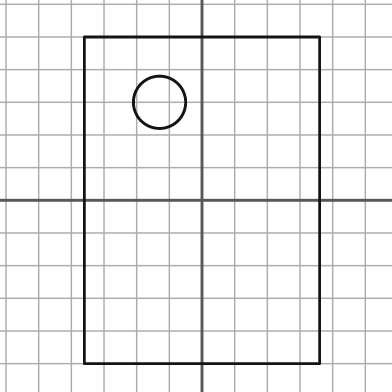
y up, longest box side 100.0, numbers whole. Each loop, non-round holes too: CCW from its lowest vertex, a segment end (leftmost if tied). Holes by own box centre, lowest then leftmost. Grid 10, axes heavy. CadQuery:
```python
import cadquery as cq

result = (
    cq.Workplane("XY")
    .moveTo(-36.0, -50.0)
    .lineTo(36.0, -50.0)
    .lineTo(36.0, 50.0)
    .lineTo(-36.0, 50.0)
    .close()
    .moveTo(-13.0, 30.0)
    .circle(8.0)
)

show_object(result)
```